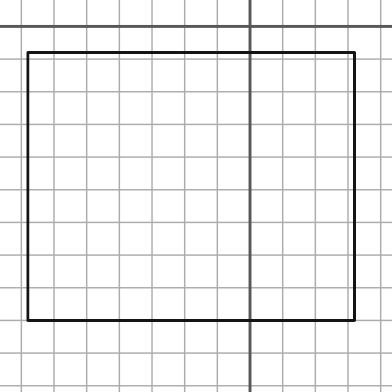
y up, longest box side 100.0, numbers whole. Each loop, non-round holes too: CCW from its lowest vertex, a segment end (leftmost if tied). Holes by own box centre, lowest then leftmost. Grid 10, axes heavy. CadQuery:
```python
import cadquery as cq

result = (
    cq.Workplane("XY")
    .moveTo(-68.0, -90.0)
    .lineTo(32.0, -90.0)
    .lineTo(32.0, -8.0)
    .lineTo(-68.0, -8.0)
    .close()
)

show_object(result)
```